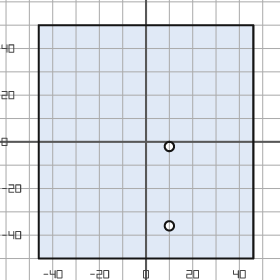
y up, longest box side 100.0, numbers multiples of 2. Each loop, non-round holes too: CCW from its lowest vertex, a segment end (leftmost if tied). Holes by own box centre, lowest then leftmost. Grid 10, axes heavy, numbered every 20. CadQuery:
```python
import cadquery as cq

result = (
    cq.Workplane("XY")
    .moveTo(-46.0, -50.0)
    .lineTo(46.0, -50.0)
    .lineTo(46.0, 50.0)
    .lineTo(-46.0, 50.0)
    .close()
    .moveTo(10.0, -36.0)
    .circle(2.0)
    .moveTo(10.0, -2.0)
    .circle(2.0)
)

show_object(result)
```